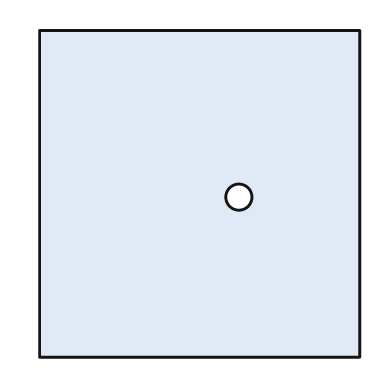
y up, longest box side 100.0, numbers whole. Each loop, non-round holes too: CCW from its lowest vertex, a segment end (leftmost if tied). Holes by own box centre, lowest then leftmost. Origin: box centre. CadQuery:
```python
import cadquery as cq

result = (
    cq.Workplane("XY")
    .moveTo(-49.0, -50.0)
    .lineTo(49.0, -50.0)
    .lineTo(49.0, 50.0)
    .lineTo(-49.0, 50.0)
    .close()
    .moveTo(12.0, -1.0)
    .circle(4.0)
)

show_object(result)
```